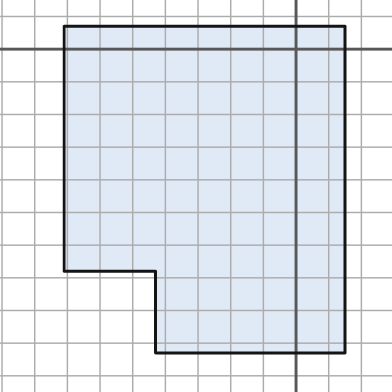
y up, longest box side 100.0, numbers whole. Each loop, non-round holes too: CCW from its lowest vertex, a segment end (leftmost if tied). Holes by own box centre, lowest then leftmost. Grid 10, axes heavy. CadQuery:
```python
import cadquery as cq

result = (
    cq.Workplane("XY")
    .moveTo(-43.0, -93.0)
    .lineTo(15.0, -93.0)
    .lineTo(15.0, 7.0)
    .lineTo(-71.0, 7.0)
    .lineTo(-71.0, -68.0)
    .lineTo(-43.0, -68.0)
    .close()
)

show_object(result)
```